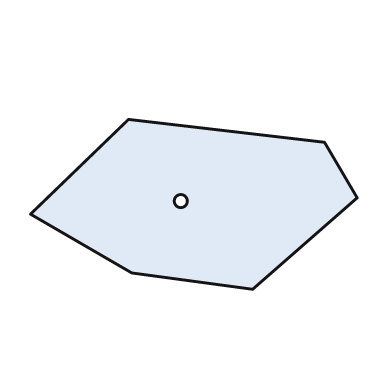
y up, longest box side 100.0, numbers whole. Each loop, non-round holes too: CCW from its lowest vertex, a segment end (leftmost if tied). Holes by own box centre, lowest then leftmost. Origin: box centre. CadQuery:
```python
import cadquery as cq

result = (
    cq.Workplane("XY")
    .moveTo(18.0, -26.0)
    .lineTo(50.0, 2.0)
    .lineTo(40.0, 19.0)
    .lineTo(-20.0, 26.0)
    .lineTo(-50.0, -3.0)
    .lineTo(-19.0, -21.0)
    .close()
    .moveTo(-4.0, 1.0)
    .circle(2.0)
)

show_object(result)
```